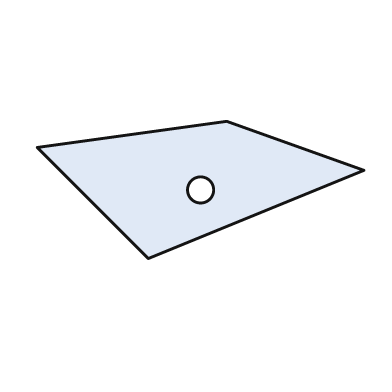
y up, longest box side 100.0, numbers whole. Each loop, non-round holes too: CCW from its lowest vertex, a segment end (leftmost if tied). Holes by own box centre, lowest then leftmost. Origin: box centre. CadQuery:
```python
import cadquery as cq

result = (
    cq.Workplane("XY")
    .moveTo(-16.0, -21.0)
    .lineTo(50.0, 6.0)
    .lineTo(8.0, 21.0)
    .lineTo(-50.0, 13.0)
    .close()
    .moveTo(0.0, 0.0)
    .circle(4.0)
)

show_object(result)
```